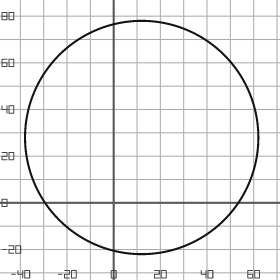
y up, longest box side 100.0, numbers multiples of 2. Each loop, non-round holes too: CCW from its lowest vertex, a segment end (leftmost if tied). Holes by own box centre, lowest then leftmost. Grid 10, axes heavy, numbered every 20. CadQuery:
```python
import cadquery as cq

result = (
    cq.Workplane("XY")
    .moveTo(12.0, 28.0)
    .circle(50.0)
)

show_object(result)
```